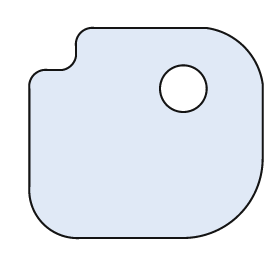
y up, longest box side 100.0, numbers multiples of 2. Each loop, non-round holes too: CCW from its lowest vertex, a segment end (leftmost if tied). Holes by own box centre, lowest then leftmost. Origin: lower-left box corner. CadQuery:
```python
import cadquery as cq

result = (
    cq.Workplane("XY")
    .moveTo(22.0, 0.0)
    .lineTo(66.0, 0.0)
    .threePointArc((90.0, 10.0), (100.0, 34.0))
    .lineTo(100.0, 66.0)
    .threePointArc((92.0, 82.0), (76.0, 90.0))
    .lineTo(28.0, 90.0)
    .threePointArc((22.0, 88.0), (20.0, 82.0))
    .lineTo(20.0, 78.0)
    .threePointArc((18.0, 74.0), (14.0, 72.0))
    .lineTo(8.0, 72.0)
    .threePointArc((2.0, 70.0), (0.0, 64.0))
    .lineTo(0.0, 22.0)
    .threePointArc((6.0, 6.0), (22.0, 0.0))
    .close()
    .moveTo(66.0, 64.0)
    .circle(10.0)
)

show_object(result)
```